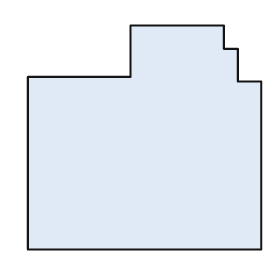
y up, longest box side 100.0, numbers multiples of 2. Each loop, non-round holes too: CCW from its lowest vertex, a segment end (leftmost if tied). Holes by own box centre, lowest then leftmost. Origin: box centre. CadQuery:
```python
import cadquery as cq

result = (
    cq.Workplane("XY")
    .moveTo(-50.0, -48.0)
    .lineTo(50.0, -48.0)
    .lineTo(50.0, 24.0)
    .lineTo(40.0, 24.0)
    .lineTo(40.0, 38.0)
    .lineTo(34.0, 38.0)
    .lineTo(34.0, 48.0)
    .lineTo(-6.0, 48.0)
    .lineTo(-6.0, 26.0)
    .lineTo(-50.0, 26.0)
    .close()
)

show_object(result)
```